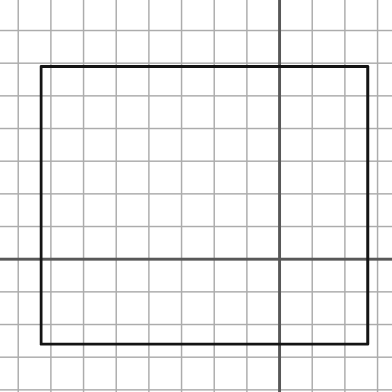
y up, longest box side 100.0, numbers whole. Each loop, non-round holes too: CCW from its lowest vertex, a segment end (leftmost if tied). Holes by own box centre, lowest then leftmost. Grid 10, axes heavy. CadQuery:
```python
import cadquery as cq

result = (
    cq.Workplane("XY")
    .moveTo(-73.0, -26.0)
    .lineTo(27.0, -26.0)
    .lineTo(27.0, 59.0)
    .lineTo(-73.0, 59.0)
    .close()
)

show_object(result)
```